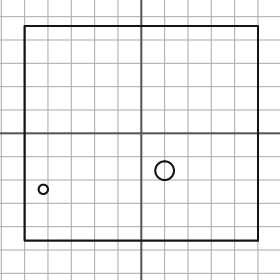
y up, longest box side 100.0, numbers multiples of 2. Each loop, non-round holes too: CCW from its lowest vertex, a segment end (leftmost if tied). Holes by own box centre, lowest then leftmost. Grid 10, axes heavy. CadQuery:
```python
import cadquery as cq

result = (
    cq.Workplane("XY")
    .moveTo(-50.0, -46.0)
    .lineTo(50.0, -46.0)
    .lineTo(50.0, 46.0)
    .lineTo(-50.0, 46.0)
    .close()
    .moveTo(-42.0, -24.0)
    .circle(2.0)
    .moveTo(10.0, -16.0)
    .circle(4.0)
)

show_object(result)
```